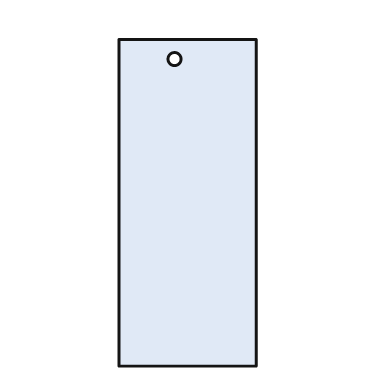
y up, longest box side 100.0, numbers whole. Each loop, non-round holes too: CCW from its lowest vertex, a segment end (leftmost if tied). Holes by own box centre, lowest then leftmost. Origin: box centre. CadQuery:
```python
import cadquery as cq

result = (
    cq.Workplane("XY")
    .moveTo(-21.0, -50.0)
    .lineTo(21.0, -50.0)
    .lineTo(21.0, 50.0)
    .lineTo(-21.0, 50.0)
    .close()
    .moveTo(-4.0, 44.0)
    .circle(2.0)
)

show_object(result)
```